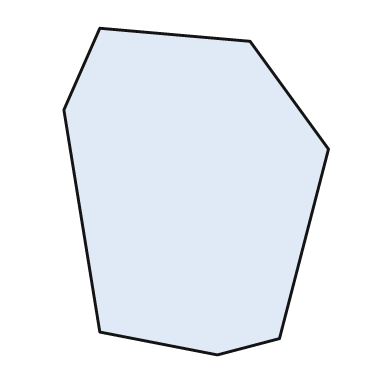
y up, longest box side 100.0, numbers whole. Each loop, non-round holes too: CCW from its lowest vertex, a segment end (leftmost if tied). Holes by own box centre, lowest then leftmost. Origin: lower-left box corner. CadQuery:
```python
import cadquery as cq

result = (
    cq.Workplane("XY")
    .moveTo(47.0, 0.0)
    .lineTo(66.0, 5.0)
    .lineTo(81.0, 63.0)
    .lineTo(57.0, 96.0)
    .lineTo(11.0, 100.0)
    .lineTo(0.0, 75.0)
    .lineTo(11.0, 7.0)
    .close()
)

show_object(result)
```